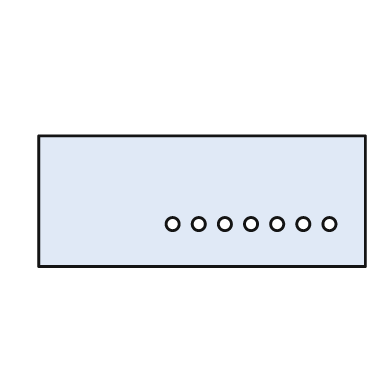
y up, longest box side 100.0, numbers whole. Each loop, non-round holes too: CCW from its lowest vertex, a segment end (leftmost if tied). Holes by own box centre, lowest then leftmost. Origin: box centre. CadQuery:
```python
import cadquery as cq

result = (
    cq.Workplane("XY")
    .moveTo(-50.0, -20.0)
    .lineTo(50.0, -20.0)
    .lineTo(50.0, 20.0)
    .lineTo(-50.0, 20.0)
    .close()
    .moveTo(-9.0, -7.0)
    .circle(2.0)
    .moveTo(-1.0, -7.0)
    .circle(2.0)
    .moveTo(7.0, -7.0)
    .circle(2.0)
    .moveTo(15.0, -7.0)
    .circle(2.0)
    .moveTo(23.0, -7.0)
    .circle(2.0)
    .moveTo(31.0, -7.0)
    .circle(2.0)
    .moveTo(39.0, -7.0)
    .circle(2.0)
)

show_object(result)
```